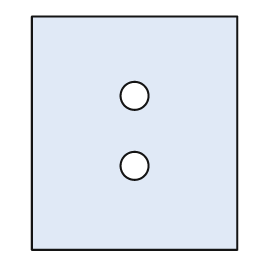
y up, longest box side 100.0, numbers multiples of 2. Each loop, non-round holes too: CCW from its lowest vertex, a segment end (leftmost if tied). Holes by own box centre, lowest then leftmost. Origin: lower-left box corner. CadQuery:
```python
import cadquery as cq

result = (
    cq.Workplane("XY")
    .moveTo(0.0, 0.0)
    .lineTo(88.0, 0.0)
    .lineTo(88.0, 100.0)
    .lineTo(0.0, 100.0)
    .close()
    .moveTo(44.0, 36.0)
    .circle(6.0)
    .moveTo(44.0, 66.0)
    .circle(6.0)
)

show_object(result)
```